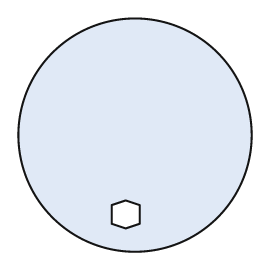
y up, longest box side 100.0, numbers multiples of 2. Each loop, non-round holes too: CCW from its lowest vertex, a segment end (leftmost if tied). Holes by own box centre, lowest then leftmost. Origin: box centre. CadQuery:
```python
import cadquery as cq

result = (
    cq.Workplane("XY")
    .moveTo(0.0, 0.0)
    .circle(50.0)
    .moveTo(-4.0, -40.0)
    .lineTo(2.0, -38.0)
    .lineTo(2.0, -30.0)
    .lineTo(-4.0, -28.0)
    .lineTo(-10.0, -30.0)
    .lineTo(-10.0, -38.0)
    .close()
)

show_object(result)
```